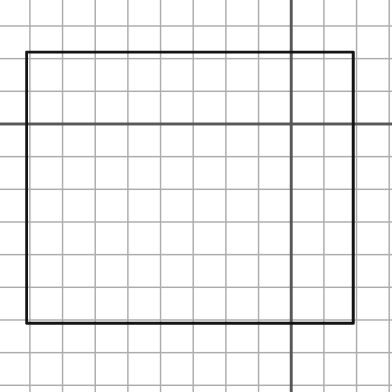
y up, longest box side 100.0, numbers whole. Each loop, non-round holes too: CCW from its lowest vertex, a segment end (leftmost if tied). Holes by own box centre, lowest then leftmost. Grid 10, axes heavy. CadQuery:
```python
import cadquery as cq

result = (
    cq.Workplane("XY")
    .moveTo(-81.0, -61.0)
    .lineTo(19.0, -61.0)
    .lineTo(19.0, 22.0)
    .lineTo(-81.0, 22.0)
    .close()
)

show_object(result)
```